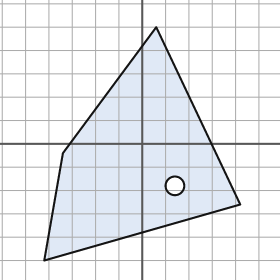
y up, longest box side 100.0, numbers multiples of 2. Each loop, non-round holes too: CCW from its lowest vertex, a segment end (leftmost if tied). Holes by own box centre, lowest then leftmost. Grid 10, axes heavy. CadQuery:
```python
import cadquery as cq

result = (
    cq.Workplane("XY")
    .moveTo(-42.0, -50.0)
    .lineTo(42.0, -26.0)
    .lineTo(6.0, 50.0)
    .lineTo(-34.0, -4.0)
    .close()
    .moveTo(14.0, -18.0)
    .circle(4.0)
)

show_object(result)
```